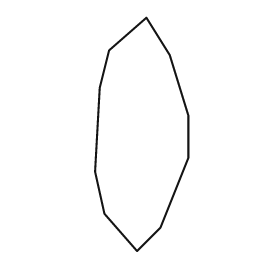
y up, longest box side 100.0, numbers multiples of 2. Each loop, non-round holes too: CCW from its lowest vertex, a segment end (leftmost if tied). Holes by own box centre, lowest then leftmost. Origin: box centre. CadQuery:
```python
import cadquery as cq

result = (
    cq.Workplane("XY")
    .moveTo(-2.0, -50.0)
    .lineTo(8.0, -40.0)
    .lineTo(20.0, -10.0)
    .lineTo(20.0, 8.0)
    .lineTo(12.0, 34.0)
    .lineTo(2.0, 50.0)
    .lineTo(-14.0, 36.0)
    .lineTo(-18.0, 20.0)
    .lineTo(-20.0, -16.0)
    .lineTo(-16.0, -34.0)
    .close()
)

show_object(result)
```